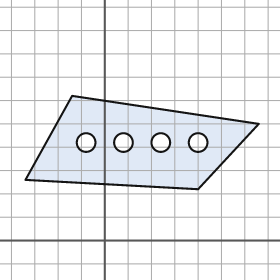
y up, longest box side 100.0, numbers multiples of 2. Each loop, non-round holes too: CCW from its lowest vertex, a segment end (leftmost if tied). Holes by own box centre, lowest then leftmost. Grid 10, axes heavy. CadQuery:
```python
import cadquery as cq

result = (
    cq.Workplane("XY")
    .moveTo(40.0, 22.0)
    .lineTo(66.0, 50.0)
    .lineTo(-14.0, 62.0)
    .lineTo(-34.0, 26.0)
    .close()
    .moveTo(-8.0, 42.0)
    .circle(4.0)
    .moveTo(8.0, 42.0)
    .circle(4.0)
    .moveTo(24.0, 42.0)
    .circle(4.0)
    .moveTo(40.0, 42.0)
    .circle(4.0)
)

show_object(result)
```